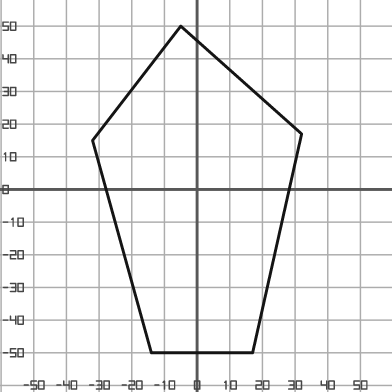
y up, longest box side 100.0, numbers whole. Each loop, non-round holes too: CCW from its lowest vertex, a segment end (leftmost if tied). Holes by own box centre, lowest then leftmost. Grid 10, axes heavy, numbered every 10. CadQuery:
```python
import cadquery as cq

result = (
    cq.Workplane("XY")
    .moveTo(-14.0, -50.0)
    .lineTo(17.0, -50.0)
    .lineTo(32.0, 17.0)
    .lineTo(-5.0, 50.0)
    .lineTo(-32.0, 15.0)
    .close()
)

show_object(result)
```